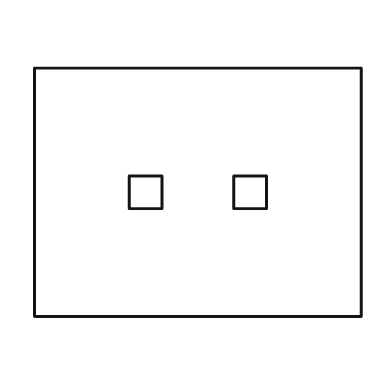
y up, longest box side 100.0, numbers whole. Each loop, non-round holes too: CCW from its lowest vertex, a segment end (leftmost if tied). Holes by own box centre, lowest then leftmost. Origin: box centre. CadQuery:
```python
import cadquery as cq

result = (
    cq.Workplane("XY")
    .moveTo(-50.0, -38.0)
    .lineTo(50.0, -38.0)
    .lineTo(50.0, 38.0)
    .lineTo(-50.0, 38.0)
    .close()
    .moveTo(-21.0, -5.0)
    .lineTo(-11.0, -5.0)
    .lineTo(-11.0, 5.0)
    .lineTo(-21.0, 5.0)
    .close()
    .moveTo(11.0, -5.0)
    .lineTo(21.0, -5.0)
    .lineTo(21.0, 5.0)
    .lineTo(11.0, 5.0)
    .close()
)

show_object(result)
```